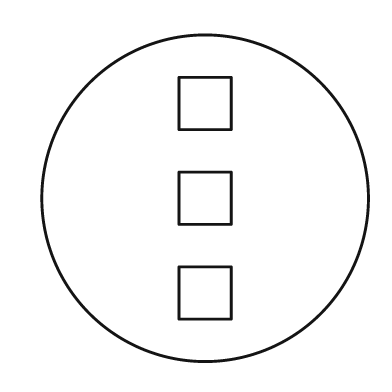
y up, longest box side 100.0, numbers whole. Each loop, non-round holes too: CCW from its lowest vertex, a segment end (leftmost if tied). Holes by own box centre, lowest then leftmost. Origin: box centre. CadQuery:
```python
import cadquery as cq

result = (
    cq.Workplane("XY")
    .moveTo(0.0, 0.0)
    .circle(50.0)
    .moveTo(-8.0, -37.0)
    .lineTo(8.0, -37.0)
    .lineTo(8.0, -21.0)
    .lineTo(-8.0, -21.0)
    .close()
    .moveTo(-8.0, -8.0)
    .lineTo(8.0, -8.0)
    .lineTo(8.0, 8.0)
    .lineTo(-8.0, 8.0)
    .close()
    .moveTo(-8.0, 21.0)
    .lineTo(8.0, 21.0)
    .lineTo(8.0, 37.0)
    .lineTo(-8.0, 37.0)
    .close()
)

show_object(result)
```